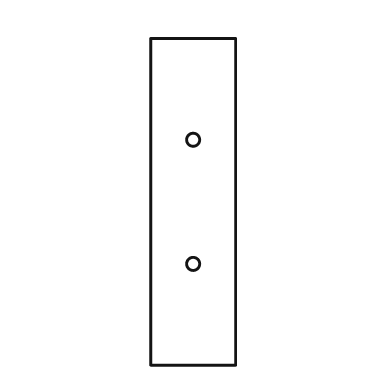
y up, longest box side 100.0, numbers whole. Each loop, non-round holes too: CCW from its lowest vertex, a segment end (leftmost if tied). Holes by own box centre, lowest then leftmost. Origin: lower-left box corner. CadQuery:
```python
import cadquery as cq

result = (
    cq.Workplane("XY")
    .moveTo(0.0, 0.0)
    .lineTo(26.0, 0.0)
    .lineTo(26.0, 100.0)
    .lineTo(0.0, 100.0)
    .close()
    .moveTo(13.0, 31.0)
    .circle(2.0)
    .moveTo(13.0, 69.0)
    .circle(2.0)
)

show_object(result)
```